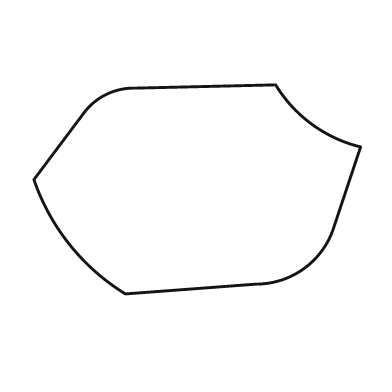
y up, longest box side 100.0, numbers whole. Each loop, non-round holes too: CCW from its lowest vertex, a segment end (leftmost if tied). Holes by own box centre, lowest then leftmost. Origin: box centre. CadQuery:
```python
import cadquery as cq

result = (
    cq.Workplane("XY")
    .moveTo(-22.0, -32.0)
    .lineTo(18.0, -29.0)
    .threePointArc((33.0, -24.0), (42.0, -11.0))
    .lineTo(50.0, 13.0)
    .threePointArc((35.0, 20.0), (24.0, 32.0))
    .lineTo(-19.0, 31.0)
    .threePointArc((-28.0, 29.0), (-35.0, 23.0))
    .lineTo(-50.0, 3.0)
    .threePointArc((-39.0, -17.0), (-22.0, -32.0))
    .close()
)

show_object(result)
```